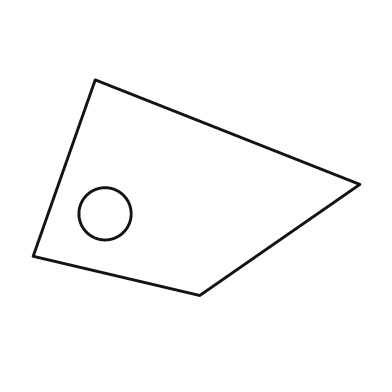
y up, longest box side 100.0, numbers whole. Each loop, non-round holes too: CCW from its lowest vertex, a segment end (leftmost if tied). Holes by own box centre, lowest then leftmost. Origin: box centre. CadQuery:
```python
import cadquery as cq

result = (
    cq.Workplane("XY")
    .moveTo(1.0, -33.0)
    .lineTo(50.0, 1.0)
    .lineTo(-31.0, 33.0)
    .lineTo(-50.0, -21.0)
    .close()
    .moveTo(-28.0, -8.0)
    .circle(8.0)
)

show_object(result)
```